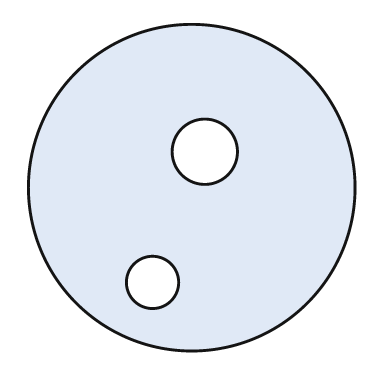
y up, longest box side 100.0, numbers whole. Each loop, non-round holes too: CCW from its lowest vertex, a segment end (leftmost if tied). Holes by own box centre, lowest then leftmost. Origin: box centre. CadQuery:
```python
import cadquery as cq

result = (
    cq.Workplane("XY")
    .moveTo(0.0, 0.0)
    .circle(50.0)
    .moveTo(-12.0, -29.0)
    .circle(8.0)
    .moveTo(4.0, 11.0)
    .circle(10.0)
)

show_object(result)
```